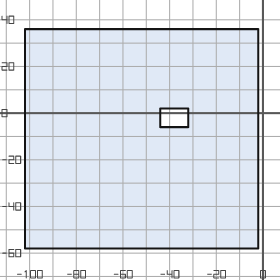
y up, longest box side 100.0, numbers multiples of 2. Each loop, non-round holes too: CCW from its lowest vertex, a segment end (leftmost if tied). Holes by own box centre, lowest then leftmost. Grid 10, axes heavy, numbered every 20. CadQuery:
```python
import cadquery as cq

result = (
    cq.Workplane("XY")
    .moveTo(-102.0, -58.0)
    .lineTo(-2.0, -58.0)
    .lineTo(-2.0, 36.0)
    .lineTo(-102.0, 36.0)
    .close()
    .moveTo(-44.0, -6.0)
    .lineTo(-32.0, -6.0)
    .lineTo(-32.0, 2.0)
    .lineTo(-44.0, 2.0)
    .close()
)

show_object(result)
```